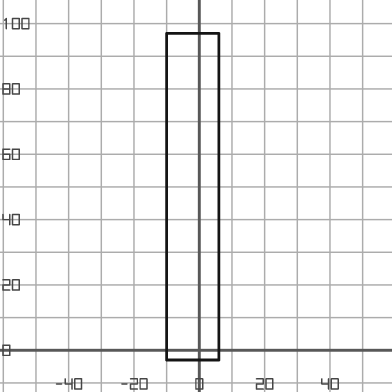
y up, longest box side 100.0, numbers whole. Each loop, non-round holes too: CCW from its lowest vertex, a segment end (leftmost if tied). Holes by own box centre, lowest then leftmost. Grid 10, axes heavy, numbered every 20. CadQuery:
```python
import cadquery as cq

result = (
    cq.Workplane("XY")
    .moveTo(-10.0, -3.0)
    .lineTo(6.0, -3.0)
    .lineTo(6.0, 97.0)
    .lineTo(-10.0, 97.0)
    .close()
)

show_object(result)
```